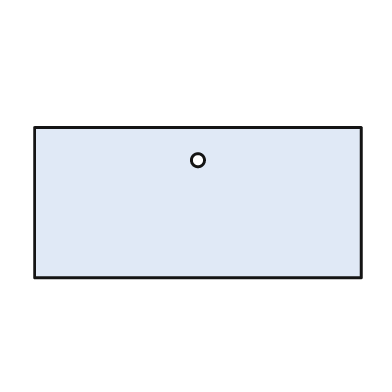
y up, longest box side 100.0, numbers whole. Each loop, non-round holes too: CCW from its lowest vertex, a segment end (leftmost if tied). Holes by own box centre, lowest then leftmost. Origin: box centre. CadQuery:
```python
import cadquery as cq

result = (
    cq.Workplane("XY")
    .moveTo(-50.0, -23.0)
    .lineTo(50.0, -23.0)
    .lineTo(50.0, 23.0)
    .lineTo(-50.0, 23.0)
    .close()
    .moveTo(0.0, 13.0)
    .circle(2.0)
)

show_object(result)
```